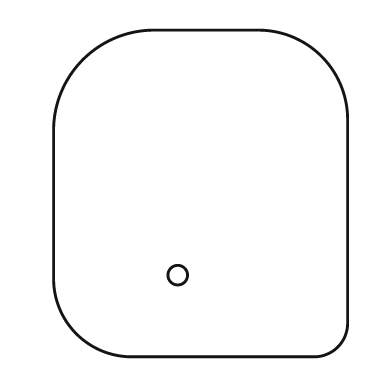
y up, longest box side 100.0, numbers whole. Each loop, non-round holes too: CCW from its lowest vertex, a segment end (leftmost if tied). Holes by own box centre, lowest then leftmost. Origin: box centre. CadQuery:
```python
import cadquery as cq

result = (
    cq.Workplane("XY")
    .moveTo(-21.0, -50.0)
    .lineTo(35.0, -50.0)
    .threePointArc((42.0, -47.0), (45.0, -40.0))
    .lineTo(45.0, 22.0)
    .threePointArc((37.0, 42.0), (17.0, 50.0))
    .lineTo(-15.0, 50.0)
    .threePointArc((-36.0, 41.0), (-45.0, 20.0))
    .lineTo(-45.0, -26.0)
    .threePointArc((-38.0, -43.0), (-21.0, -50.0))
    .close()
    .moveTo(-7.0, -25.0)
    .circle(3.0)
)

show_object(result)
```